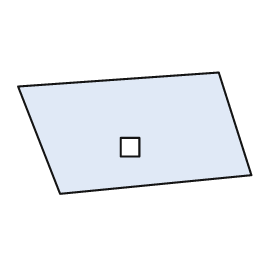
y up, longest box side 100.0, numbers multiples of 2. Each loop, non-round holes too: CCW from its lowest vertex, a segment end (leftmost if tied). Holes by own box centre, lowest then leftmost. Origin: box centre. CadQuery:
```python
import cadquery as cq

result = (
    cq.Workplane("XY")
    .moveTo(-32.0, -26.0)
    .lineTo(50.0, -18.0)
    .lineTo(36.0, 26.0)
    .lineTo(-50.0, 20.0)
    .close()
    .moveTo(-6.0, -10.0)
    .lineTo(2.0, -10.0)
    .lineTo(2.0, -2.0)
    .lineTo(-6.0, -2.0)
    .close()
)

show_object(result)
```